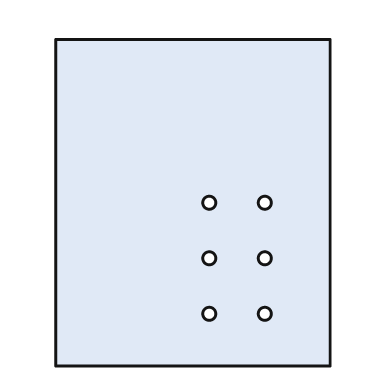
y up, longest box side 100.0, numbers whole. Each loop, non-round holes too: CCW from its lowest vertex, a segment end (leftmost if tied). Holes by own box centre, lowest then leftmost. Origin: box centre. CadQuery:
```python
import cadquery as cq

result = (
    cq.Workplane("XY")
    .moveTo(-42.0, -50.0)
    .lineTo(42.0, -50.0)
    .lineTo(42.0, 50.0)
    .lineTo(-42.0, 50.0)
    .close()
    .moveTo(5.0, -34.0)
    .circle(2.0)
    .moveTo(22.0, -34.0)
    .circle(2.0)
    .moveTo(5.0, -17.0)
    .circle(2.0)
    .moveTo(22.0, -17.0)
    .circle(2.0)
    .moveTo(5.0, 0.0)
    .circle(2.0)
    .moveTo(22.0, 0.0)
    .circle(2.0)
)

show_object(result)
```